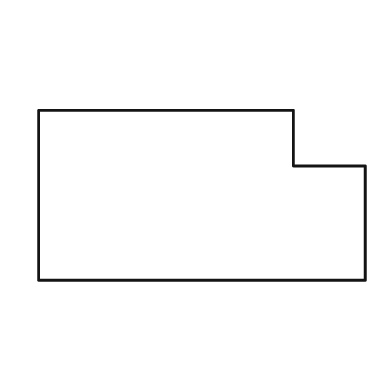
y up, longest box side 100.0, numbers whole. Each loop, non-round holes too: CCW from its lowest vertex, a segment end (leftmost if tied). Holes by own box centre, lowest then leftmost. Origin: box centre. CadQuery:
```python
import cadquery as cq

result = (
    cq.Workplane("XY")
    .moveTo(-50.0, -26.0)
    .lineTo(50.0, -26.0)
    .lineTo(50.0, 9.0)
    .lineTo(28.0, 9.0)
    .lineTo(28.0, 26.0)
    .lineTo(-50.0, 26.0)
    .close()
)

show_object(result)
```